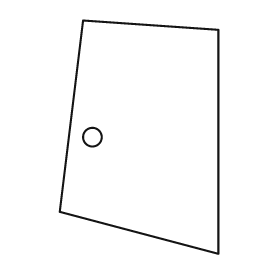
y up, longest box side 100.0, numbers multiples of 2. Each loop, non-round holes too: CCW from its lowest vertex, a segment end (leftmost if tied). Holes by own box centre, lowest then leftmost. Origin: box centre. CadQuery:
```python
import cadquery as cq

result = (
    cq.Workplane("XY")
    .moveTo(34.0, -50.0)
    .lineTo(34.0, 46.0)
    .lineTo(-24.0, 50.0)
    .lineTo(-34.0, -32.0)
    .close()
    .moveTo(-20.0, 0.0)
    .circle(4.0)
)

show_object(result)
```